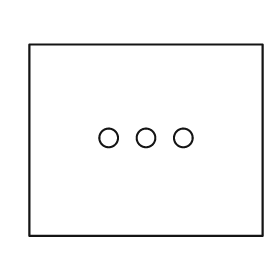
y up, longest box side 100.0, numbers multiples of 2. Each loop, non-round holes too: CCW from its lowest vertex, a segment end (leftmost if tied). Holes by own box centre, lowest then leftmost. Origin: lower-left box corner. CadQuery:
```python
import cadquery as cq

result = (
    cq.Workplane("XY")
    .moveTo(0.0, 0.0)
    .lineTo(100.0, 0.0)
    .lineTo(100.0, 82.0)
    .lineTo(0.0, 82.0)
    .close()
    .moveTo(34.0, 42.0)
    .circle(4.0)
    .moveTo(50.0, 42.0)
    .circle(4.0)
    .moveTo(66.0, 42.0)
    .circle(4.0)
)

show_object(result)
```